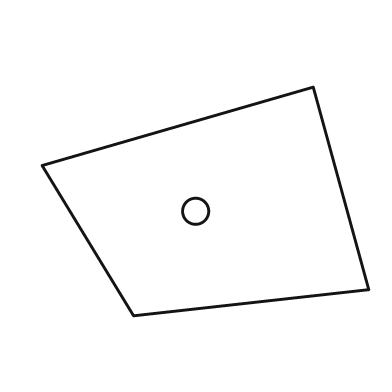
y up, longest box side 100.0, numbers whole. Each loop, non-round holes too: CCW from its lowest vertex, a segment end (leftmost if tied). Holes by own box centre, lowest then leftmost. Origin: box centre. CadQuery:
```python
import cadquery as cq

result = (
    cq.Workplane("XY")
    .moveTo(-22.0, -35.0)
    .lineTo(50.0, -27.0)
    .lineTo(33.0, 35.0)
    .lineTo(-50.0, 11.0)
    .close()
    .moveTo(-3.0, -3.0)
    .circle(4.0)
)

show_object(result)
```